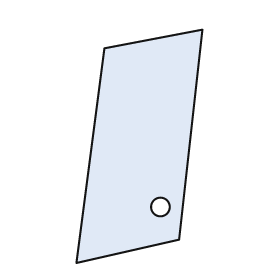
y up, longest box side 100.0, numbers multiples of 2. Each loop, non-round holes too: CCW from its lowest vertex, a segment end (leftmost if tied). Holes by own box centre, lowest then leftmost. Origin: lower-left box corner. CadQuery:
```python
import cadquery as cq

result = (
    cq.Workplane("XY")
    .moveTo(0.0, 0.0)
    .lineTo(44.0, 10.0)
    .lineTo(54.0, 100.0)
    .lineTo(12.0, 92.0)
    .close()
    .moveTo(36.0, 24.0)
    .circle(4.0)
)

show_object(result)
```